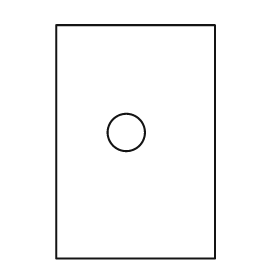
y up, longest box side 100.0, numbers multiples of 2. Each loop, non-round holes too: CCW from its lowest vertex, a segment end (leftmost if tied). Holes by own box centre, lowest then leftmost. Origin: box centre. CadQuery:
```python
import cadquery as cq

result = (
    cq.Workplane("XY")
    .moveTo(-34.0, -50.0)
    .lineTo(34.0, -50.0)
    .lineTo(34.0, 50.0)
    .lineTo(-34.0, 50.0)
    .close()
    .moveTo(-4.0, 4.0)
    .circle(8.0)
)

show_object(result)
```